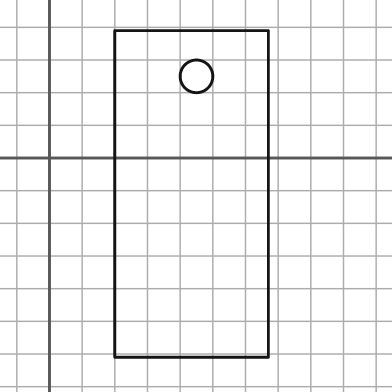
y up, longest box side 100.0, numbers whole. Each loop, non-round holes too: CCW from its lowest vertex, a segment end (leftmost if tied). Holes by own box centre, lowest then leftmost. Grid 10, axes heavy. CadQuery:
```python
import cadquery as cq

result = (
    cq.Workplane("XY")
    .moveTo(20.0, -61.0)
    .lineTo(67.0, -61.0)
    .lineTo(67.0, 39.0)
    .lineTo(20.0, 39.0)
    .close()
    .moveTo(45.0, 25.0)
    .circle(5.0)
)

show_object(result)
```